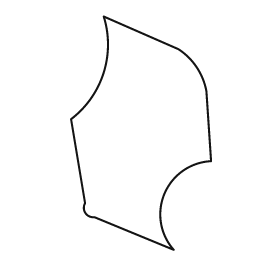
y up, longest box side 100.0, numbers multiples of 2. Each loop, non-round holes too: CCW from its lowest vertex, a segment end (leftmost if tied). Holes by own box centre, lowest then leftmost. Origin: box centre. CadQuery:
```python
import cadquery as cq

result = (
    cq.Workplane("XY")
    .moveTo(14.0, -50.0)
    .threePointArc((10.0, -26.0), (30.0, -12.0))
    .lineTo(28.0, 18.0)
    .threePointArc((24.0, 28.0), (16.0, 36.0))
    .lineTo(-16.0, 50.0)
    .threePointArc((-16.0, 26.0), (-30.0, 6.0))
    .lineTo(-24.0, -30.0)
    .threePointArc((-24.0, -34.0), (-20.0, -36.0))
    .close()
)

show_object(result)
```